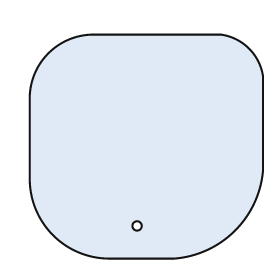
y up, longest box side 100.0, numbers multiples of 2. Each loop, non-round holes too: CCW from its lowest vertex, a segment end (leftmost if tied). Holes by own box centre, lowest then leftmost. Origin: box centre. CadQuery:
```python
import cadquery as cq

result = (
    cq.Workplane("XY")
    .moveTo(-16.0, -48.0)
    .lineTo(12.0, -48.0)
    .threePointArc((38.0, -36.0), (50.0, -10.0))
    .lineTo(50.0, 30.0)
    .threePointArc((44.0, 42.0), (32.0, 48.0))
    .lineTo(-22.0, 48.0)
    .threePointArc((-42.0, 40.0), (-50.0, 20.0))
    .lineTo(-50.0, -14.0)
    .threePointArc((-40.0, -38.0), (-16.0, -48.0))
    .close()
    .moveTo(-4.0, -34.0)
    .circle(2.0)
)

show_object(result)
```